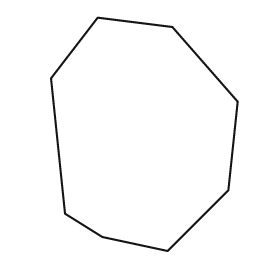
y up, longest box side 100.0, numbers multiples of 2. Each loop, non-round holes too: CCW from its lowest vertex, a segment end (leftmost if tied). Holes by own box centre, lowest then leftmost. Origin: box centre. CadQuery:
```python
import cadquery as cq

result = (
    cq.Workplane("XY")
    .moveTo(10.0, -50.0)
    .lineTo(36.0, -24.0)
    .lineTo(40.0, 14.0)
    .lineTo(12.0, 46.0)
    .lineTo(-20.0, 50.0)
    .lineTo(-40.0, 24.0)
    .lineTo(-34.0, -34.0)
    .lineTo(-18.0, -44.0)
    .close()
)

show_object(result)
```